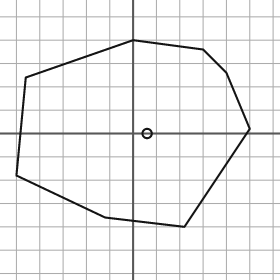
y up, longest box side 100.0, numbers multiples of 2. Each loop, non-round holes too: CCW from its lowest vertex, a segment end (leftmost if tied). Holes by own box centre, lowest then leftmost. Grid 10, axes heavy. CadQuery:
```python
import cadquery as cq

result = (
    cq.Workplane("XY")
    .moveTo(22.0, -40.0)
    .lineTo(50.0, 2.0)
    .lineTo(40.0, 26.0)
    .lineTo(30.0, 36.0)
    .lineTo(0.0, 40.0)
    .lineTo(-46.0, 24.0)
    .lineTo(-50.0, -18.0)
    .lineTo(-12.0, -36.0)
    .close()
    .moveTo(6.0, 0.0)
    .circle(2.0)
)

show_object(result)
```